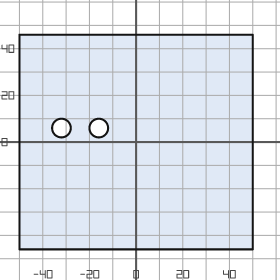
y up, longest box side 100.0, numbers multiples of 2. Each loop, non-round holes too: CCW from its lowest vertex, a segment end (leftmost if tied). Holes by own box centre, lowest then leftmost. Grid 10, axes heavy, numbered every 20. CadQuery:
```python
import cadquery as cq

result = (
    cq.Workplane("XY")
    .moveTo(-50.0, -46.0)
    .lineTo(50.0, -46.0)
    .lineTo(50.0, 46.0)
    .lineTo(-50.0, 46.0)
    .close()
    .moveTo(-32.0, 6.0)
    .circle(4.0)
    .moveTo(-16.0, 6.0)
    .circle(4.0)
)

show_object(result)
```